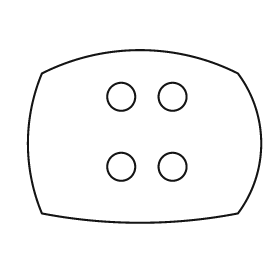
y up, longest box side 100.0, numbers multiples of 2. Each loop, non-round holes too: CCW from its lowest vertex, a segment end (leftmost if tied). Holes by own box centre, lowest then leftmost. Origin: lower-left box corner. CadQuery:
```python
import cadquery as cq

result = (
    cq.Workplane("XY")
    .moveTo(6.0, 4.0)
    .threePointArc((48.0, 0.0), (90.0, 4.0))
    .threePointArc((100.0, 34.0), (90.0, 64.0))
    .threePointArc((48.0, 74.0), (6.0, 64.0))
    .threePointArc((0.0, 34.0), (6.0, 4.0))
    .close()
    .moveTo(40.0, 24.0)
    .circle(6.0)
    .moveTo(62.0, 24.0)
    .circle(6.0)
    .moveTo(40.0, 54.0)
    .circle(6.0)
    .moveTo(62.0, 54.0)
    .circle(6.0)
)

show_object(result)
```